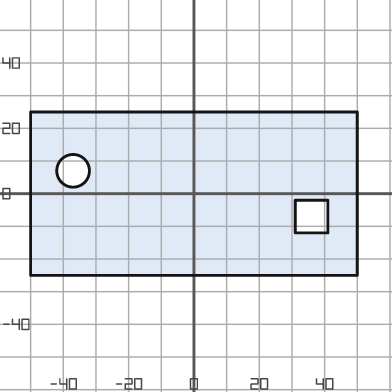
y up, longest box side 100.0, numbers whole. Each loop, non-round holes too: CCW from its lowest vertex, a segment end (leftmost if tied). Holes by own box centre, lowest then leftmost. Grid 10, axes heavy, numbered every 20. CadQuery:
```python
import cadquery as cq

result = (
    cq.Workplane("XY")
    .moveTo(-50.0, -25.0)
    .lineTo(50.0, -25.0)
    .lineTo(50.0, 25.0)
    .lineTo(-50.0, 25.0)
    .close()
    .moveTo(31.0, -12.0)
    .lineTo(41.0, -12.0)
    .lineTo(41.0, -2.0)
    .lineTo(31.0, -2.0)
    .close()
    .moveTo(-37.0, 7.0)
    .circle(5.0)
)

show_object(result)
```